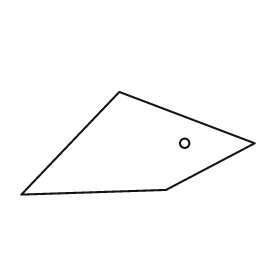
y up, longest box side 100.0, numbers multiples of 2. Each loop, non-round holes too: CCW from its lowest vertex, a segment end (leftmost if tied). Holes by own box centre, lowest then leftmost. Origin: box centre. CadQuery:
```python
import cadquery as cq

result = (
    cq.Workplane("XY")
    .moveTo(-50.0, -22.0)
    .lineTo(12.0, -20.0)
    .lineTo(50.0, 0.0)
    .lineTo(-8.0, 22.0)
    .close()
    .moveTo(20.0, 0.0)
    .circle(2.0)
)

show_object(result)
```